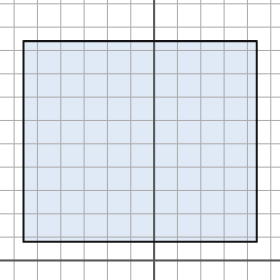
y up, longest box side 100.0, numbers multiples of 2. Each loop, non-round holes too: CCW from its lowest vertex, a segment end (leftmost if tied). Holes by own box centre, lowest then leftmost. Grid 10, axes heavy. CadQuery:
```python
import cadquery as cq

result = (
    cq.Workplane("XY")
    .moveTo(-56.0, 8.0)
    .lineTo(44.0, 8.0)
    .lineTo(44.0, 94.0)
    .lineTo(-56.0, 94.0)
    .close()
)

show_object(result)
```